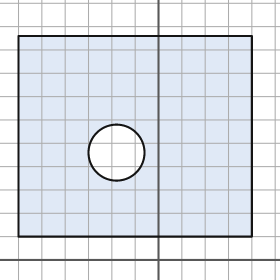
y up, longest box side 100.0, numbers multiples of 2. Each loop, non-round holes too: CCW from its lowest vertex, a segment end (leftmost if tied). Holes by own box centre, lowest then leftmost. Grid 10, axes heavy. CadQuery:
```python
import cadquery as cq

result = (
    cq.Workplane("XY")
    .moveTo(-60.0, 10.0)
    .lineTo(40.0, 10.0)
    .lineTo(40.0, 96.0)
    .lineTo(-60.0, 96.0)
    .close()
    .moveTo(-18.0, 46.0)
    .circle(12.0)
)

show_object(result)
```